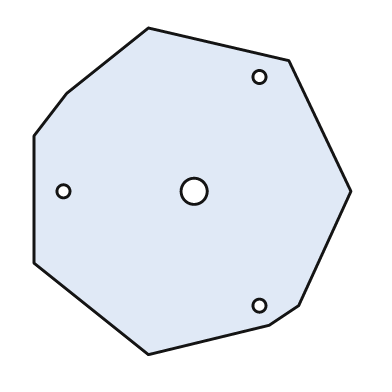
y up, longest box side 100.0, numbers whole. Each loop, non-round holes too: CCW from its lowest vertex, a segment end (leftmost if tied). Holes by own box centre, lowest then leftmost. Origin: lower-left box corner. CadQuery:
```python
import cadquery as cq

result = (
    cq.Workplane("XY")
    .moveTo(35.0, 0.0)
    .lineTo(72.0, 9.0)
    .lineTo(81.0, 15.0)
    .lineTo(97.0, 50.0)
    .lineTo(78.0, 90.0)
    .lineTo(35.0, 100.0)
    .lineTo(10.0, 80.0)
    .lineTo(0.0, 67.0)
    .lineTo(0.0, 28.0)
    .close()
    .moveTo(69.0, 15.0)
    .circle(2.0)
    .moveTo(9.0, 50.0)
    .circle(2.0)
    .moveTo(49.0, 50.0)
    .circle(4.0)
    .moveTo(69.0, 85.0)
    .circle(2.0)
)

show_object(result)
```